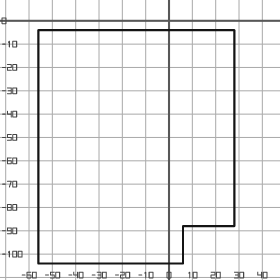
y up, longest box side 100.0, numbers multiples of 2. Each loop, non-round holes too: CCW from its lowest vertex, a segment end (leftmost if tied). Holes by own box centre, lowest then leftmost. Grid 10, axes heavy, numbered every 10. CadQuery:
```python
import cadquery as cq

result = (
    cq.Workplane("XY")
    .moveTo(-56.0, -104.0)
    .lineTo(6.0, -104.0)
    .lineTo(6.0, -88.0)
    .lineTo(28.0, -88.0)
    .lineTo(28.0, -4.0)
    .lineTo(-56.0, -4.0)
    .close()
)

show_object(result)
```